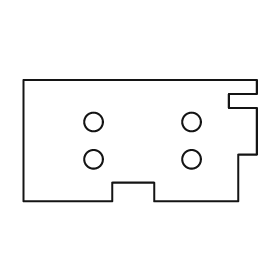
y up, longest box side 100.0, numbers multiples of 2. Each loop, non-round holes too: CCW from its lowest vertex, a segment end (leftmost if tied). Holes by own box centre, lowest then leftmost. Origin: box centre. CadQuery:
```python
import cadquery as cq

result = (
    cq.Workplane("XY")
    .moveTo(-50.0, -26.0)
    .lineTo(-12.0, -26.0)
    .lineTo(-12.0, -18.0)
    .lineTo(6.0, -18.0)
    .lineTo(6.0, -26.0)
    .lineTo(42.0, -26.0)
    .lineTo(42.0, -6.0)
    .lineTo(50.0, -6.0)
    .lineTo(50.0, 14.0)
    .lineTo(38.0, 14.0)
    .lineTo(38.0, 20.0)
    .lineTo(50.0, 20.0)
    .lineTo(50.0, 26.0)
    .lineTo(-50.0, 26.0)
    .close()
    .moveTo(-20.0, -8.0)
    .circle(4.0)
    .moveTo(22.0, -8.0)
    .circle(4.0)
    .moveTo(-20.0, 8.0)
    .circle(4.0)
    .moveTo(22.0, 8.0)
    .circle(4.0)
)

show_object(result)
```